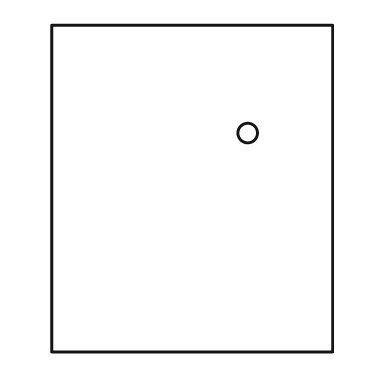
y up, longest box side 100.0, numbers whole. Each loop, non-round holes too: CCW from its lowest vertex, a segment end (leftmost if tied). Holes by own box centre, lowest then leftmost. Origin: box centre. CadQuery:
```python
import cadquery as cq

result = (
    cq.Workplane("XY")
    .moveTo(-43.0, -50.0)
    .lineTo(43.0, -50.0)
    .lineTo(43.0, 50.0)
    .lineTo(-43.0, 50.0)
    .close()
    .moveTo(17.0, 17.0)
    .circle(3.0)
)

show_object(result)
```